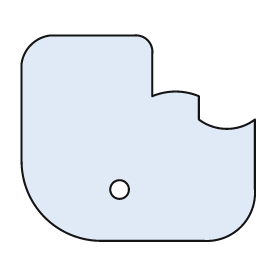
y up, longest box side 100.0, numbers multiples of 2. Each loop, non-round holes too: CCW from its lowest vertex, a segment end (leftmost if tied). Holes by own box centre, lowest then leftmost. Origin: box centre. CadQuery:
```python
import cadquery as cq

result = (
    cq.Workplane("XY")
    .moveTo(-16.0, -44.0)
    .lineTo(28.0, -44.0)
    .threePointArc((44.0, -38.0), (50.0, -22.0))
    .lineTo(50.0, 8.0)
    .threePointArc((38.0, 4.0), (26.0, 8.0))
    .lineTo(26.0, 18.0)
    .threePointArc((16.0, 20.0), (6.0, 18.0))
    .lineTo(6.0, 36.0)
    .threePointArc((4.0, 42.0), (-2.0, 44.0))
    .lineTo(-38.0, 44.0)
    .threePointArc((-46.0, 40.0), (-50.0, 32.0))
    .lineTo(-50.0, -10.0)
    .threePointArc((-40.0, -34.0), (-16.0, -44.0))
    .close()
    .moveTo(-8.0, -22.0)
    .circle(4.0)
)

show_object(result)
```